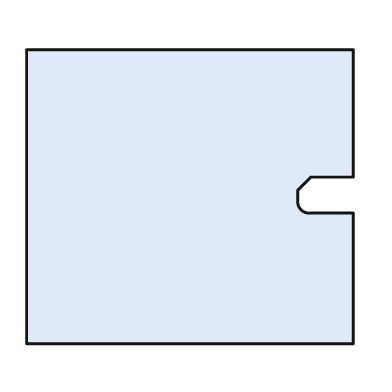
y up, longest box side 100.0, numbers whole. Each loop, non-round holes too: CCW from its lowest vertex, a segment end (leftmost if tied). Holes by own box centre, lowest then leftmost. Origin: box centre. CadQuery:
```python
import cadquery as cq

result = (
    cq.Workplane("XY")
    .moveTo(-50.0, -45.0)
    .lineTo(50.0, -45.0)
    .lineTo(50.0, -5.0)
    .lineTo(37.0, -5.0)
    .threePointArc((34.0, -4.0), (33.0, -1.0))
    .lineTo(33.0, 2.0)
    .lineTo(37.0, 6.0)
    .lineTo(50.0, 6.0)
    .lineTo(50.0, 45.0)
    .lineTo(-50.0, 45.0)
    .close()
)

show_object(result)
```